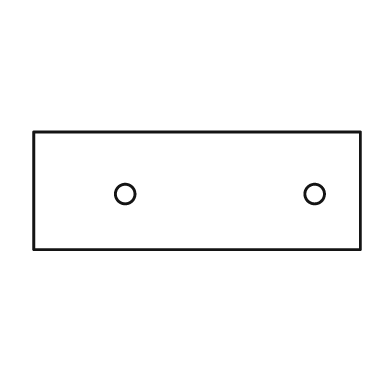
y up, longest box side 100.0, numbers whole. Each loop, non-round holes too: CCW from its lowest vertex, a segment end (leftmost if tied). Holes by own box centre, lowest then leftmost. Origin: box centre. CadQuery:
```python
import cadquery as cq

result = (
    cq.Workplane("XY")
    .moveTo(-50.0, -18.0)
    .lineTo(50.0, -18.0)
    .lineTo(50.0, 18.0)
    .lineTo(-50.0, 18.0)
    .close()
    .moveTo(-22.0, -1.0)
    .circle(3.0)
    .moveTo(36.0, -1.0)
    .circle(3.0)
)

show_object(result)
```